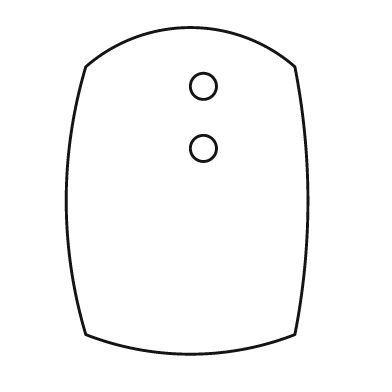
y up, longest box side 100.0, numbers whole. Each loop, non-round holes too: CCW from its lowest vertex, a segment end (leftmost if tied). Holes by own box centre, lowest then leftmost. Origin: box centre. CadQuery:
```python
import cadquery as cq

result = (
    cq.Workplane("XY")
    .moveTo(-31.0, -44.0)
    .threePointArc((1.0, -50.0), (33.0, -44.0))
    .threePointArc((37.0, -3.0), (33.0, 38.0))
    .threePointArc((1.0, 50.0), (-31.0, 38.0))
    .threePointArc((-37.0, -3.0), (-31.0, -44.0))
    .close()
    .moveTo(5.0, 13.0)
    .circle(4.0)
    .moveTo(5.0, 32.0)
    .circle(4.0)
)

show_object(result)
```